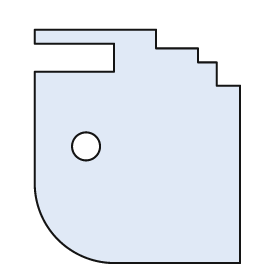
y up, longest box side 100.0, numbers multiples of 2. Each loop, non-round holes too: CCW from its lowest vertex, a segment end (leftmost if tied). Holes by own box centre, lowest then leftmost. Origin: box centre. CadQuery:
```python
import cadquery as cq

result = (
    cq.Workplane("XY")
    .moveTo(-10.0, -50.0)
    .lineTo(44.0, -50.0)
    .lineTo(44.0, 26.0)
    .lineTo(34.0, 26.0)
    .lineTo(34.0, 36.0)
    .lineTo(26.0, 36.0)
    .lineTo(26.0, 42.0)
    .lineTo(8.0, 42.0)
    .lineTo(8.0, 50.0)
    .lineTo(-44.0, 50.0)
    .lineTo(-44.0, 44.0)
    .lineTo(-10.0, 44.0)
    .lineTo(-10.0, 32.0)
    .lineTo(-44.0, 32.0)
    .lineTo(-44.0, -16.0)
    .threePointArc((-34.0, -40.0), (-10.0, -50.0))
    .close()
    .moveTo(-22.0, 0.0)
    .circle(6.0)
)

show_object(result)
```